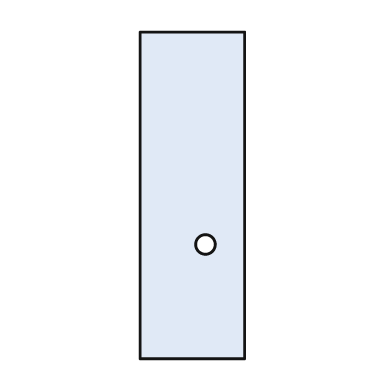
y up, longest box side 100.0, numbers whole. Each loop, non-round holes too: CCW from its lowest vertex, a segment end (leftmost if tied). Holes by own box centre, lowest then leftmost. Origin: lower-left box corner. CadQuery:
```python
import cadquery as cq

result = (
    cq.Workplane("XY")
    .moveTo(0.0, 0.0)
    .lineTo(32.0, 0.0)
    .lineTo(32.0, 100.0)
    .lineTo(0.0, 100.0)
    .close()
    .moveTo(20.0, 35.0)
    .circle(3.0)
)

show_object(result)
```